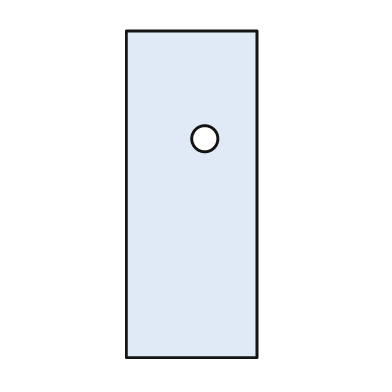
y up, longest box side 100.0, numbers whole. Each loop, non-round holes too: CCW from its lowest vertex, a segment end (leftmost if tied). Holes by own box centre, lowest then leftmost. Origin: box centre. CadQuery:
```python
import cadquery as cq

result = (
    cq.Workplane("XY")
    .moveTo(-20.0, -50.0)
    .lineTo(20.0, -50.0)
    .lineTo(20.0, 50.0)
    .lineTo(-20.0, 50.0)
    .close()
    .moveTo(4.0, 17.0)
    .circle(4.0)
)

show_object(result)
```